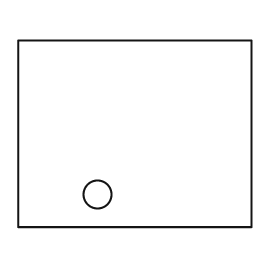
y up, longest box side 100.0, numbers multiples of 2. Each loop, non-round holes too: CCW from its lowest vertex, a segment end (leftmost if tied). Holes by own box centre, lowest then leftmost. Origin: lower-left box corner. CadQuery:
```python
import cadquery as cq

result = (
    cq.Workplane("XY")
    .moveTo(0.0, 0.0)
    .lineTo(100.0, 0.0)
    .lineTo(100.0, 80.0)
    .lineTo(0.0, 80.0)
    .close()
    .moveTo(34.0, 14.0)
    .circle(6.0)
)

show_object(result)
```